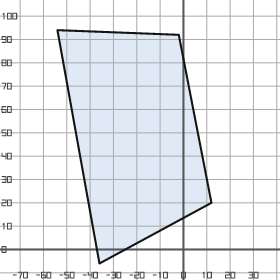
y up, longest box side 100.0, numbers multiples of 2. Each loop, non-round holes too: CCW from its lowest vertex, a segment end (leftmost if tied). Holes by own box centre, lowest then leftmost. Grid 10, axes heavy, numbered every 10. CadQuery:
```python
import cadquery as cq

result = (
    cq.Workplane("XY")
    .moveTo(-36.0, -6.0)
    .lineTo(12.0, 20.0)
    .lineTo(-2.0, 92.0)
    .lineTo(-54.0, 94.0)
    .close()
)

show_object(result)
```